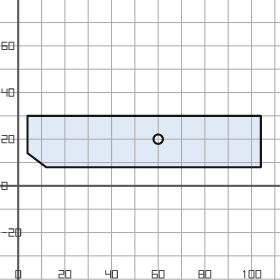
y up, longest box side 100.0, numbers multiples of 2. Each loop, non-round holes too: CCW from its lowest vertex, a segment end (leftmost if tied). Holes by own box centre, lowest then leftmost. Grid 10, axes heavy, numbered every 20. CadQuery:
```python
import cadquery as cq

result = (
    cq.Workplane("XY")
    .moveTo(12.0, 8.0)
    .lineTo(104.0, 8.0)
    .lineTo(104.0, 30.0)
    .lineTo(4.0, 30.0)
    .lineTo(4.0, 14.0)
    .close()
    .moveTo(60.0, 20.0)
    .circle(2.0)
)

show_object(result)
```